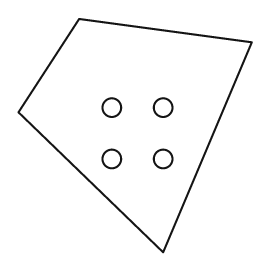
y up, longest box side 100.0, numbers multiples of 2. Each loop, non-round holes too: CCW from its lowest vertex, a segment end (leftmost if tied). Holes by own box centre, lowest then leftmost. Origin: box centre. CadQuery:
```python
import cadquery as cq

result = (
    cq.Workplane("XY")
    .moveTo(12.0, -50.0)
    .lineTo(50.0, 40.0)
    .lineTo(-24.0, 50.0)
    .lineTo(-50.0, 10.0)
    .close()
    .moveTo(-10.0, -10.0)
    .circle(4.0)
    .moveTo(12.0, -10.0)
    .circle(4.0)
    .moveTo(-10.0, 12.0)
    .circle(4.0)
    .moveTo(12.0, 12.0)
    .circle(4.0)
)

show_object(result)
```